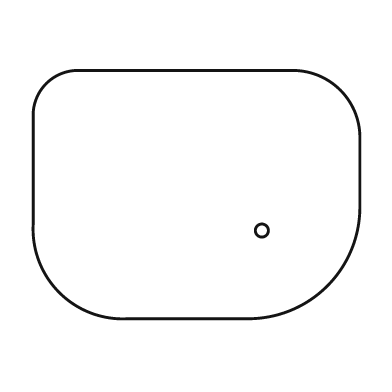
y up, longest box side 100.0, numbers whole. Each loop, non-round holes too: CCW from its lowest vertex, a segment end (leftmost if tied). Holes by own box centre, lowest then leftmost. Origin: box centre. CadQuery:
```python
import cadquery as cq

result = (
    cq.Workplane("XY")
    .moveTo(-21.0, -38.0)
    .lineTo(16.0, -38.0)
    .threePointArc((40.0, -28.0), (50.0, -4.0))
    .lineTo(50.0, 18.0)
    .threePointArc((44.0, 32.0), (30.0, 38.0))
    .lineTo(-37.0, 38.0)
    .threePointArc((-46.0, 34.0), (-50.0, 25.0))
    .lineTo(-50.0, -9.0)
    .threePointArc((-42.0, -30.0), (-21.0, -38.0))
    .close()
    .moveTo(20.0, -11.0)
    .circle(2.0)
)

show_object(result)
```